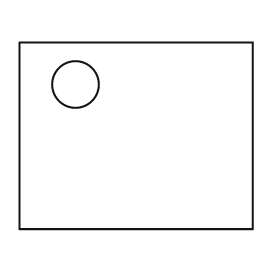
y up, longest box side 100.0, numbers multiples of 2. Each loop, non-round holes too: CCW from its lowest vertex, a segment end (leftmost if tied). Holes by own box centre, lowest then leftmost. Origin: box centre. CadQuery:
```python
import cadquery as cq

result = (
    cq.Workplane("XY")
    .moveTo(-50.0, -40.0)
    .lineTo(50.0, -40.0)
    .lineTo(50.0, 40.0)
    .lineTo(-50.0, 40.0)
    .close()
    .moveTo(-26.0, 22.0)
    .circle(10.0)
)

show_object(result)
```